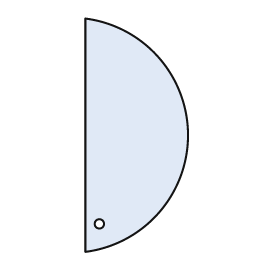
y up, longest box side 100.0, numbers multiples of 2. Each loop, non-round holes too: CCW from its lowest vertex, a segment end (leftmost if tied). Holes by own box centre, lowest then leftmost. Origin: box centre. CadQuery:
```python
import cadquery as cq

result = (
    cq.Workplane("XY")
    .moveTo(-22.0, -50.0)
    .threePointArc((22.0, 0.0), (-22.0, 50.0))
    .close()
    .moveTo(-16.0, -38.0)
    .circle(2.0)
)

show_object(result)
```